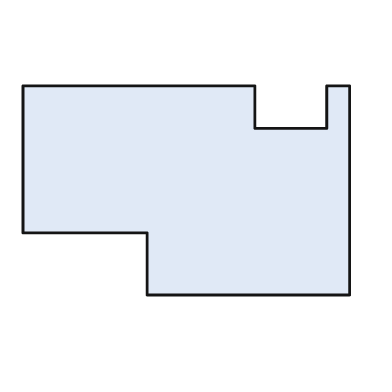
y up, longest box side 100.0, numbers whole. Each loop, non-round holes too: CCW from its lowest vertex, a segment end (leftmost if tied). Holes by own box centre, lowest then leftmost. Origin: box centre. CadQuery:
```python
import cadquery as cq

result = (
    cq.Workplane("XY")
    .moveTo(-12.0, -32.0)
    .lineTo(50.0, -32.0)
    .lineTo(50.0, 32.0)
    .lineTo(43.0, 32.0)
    .lineTo(43.0, 19.0)
    .lineTo(21.0, 19.0)
    .lineTo(21.0, 32.0)
    .lineTo(-50.0, 32.0)
    .lineTo(-50.0, -13.0)
    .lineTo(-12.0, -13.0)
    .close()
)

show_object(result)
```